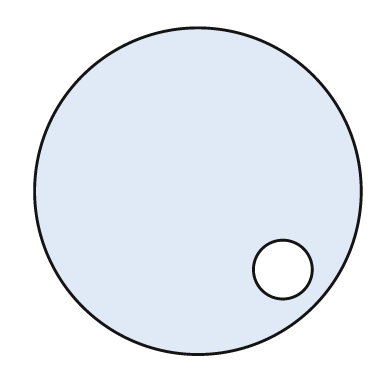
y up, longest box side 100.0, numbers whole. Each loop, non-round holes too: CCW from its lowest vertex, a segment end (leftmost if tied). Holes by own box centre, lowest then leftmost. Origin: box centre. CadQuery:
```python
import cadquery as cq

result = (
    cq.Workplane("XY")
    .moveTo(0.0, 0.0)
    .circle(50.0)
    .moveTo(26.0, -24.0)
    .circle(9.0)
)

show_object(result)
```